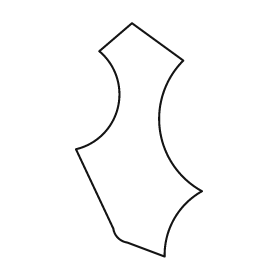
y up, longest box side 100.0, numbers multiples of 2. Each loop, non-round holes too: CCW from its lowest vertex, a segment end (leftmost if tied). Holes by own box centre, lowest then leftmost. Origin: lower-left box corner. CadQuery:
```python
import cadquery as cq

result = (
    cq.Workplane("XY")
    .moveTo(38.0, 0.0)
    .threePointArc((42.0, 16.0), (54.0, 28.0))
    .threePointArc((36.0, 54.0), (46.0, 84.0))
    .lineTo(24.0, 100.0)
    .lineTo(10.0, 88.0)
    .threePointArc((18.0, 64.0), (0.0, 46.0))
    .lineTo(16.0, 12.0)
    .threePointArc((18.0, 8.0), (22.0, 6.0))
    .close()
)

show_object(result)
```